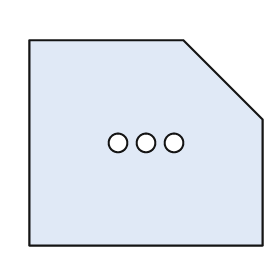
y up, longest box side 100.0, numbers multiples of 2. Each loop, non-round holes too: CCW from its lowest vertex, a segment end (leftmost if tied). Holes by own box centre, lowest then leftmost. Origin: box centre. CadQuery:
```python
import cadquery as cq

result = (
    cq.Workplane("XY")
    .moveTo(-50.0, -44.0)
    .lineTo(50.0, -44.0)
    .lineTo(50.0, 10.0)
    .lineTo(16.0, 44.0)
    .lineTo(-50.0, 44.0)
    .close()
    .moveTo(-12.0, 0.0)
    .circle(4.0)
    .moveTo(0.0, 0.0)
    .circle(4.0)
    .moveTo(12.0, 0.0)
    .circle(4.0)
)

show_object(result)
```